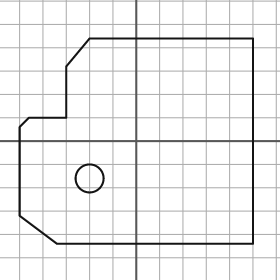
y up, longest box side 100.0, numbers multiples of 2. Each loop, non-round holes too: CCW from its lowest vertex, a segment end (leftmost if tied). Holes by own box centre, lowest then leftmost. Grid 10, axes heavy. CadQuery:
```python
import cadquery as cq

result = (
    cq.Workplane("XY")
    .moveTo(-34.0, -44.0)
    .lineTo(50.0, -44.0)
    .lineTo(50.0, 44.0)
    .lineTo(-20.0, 44.0)
    .lineTo(-30.0, 32.0)
    .lineTo(-30.0, 10.0)
    .lineTo(-46.0, 10.0)
    .lineTo(-50.0, 6.0)
    .lineTo(-50.0, -32.0)
    .close()
    .moveTo(-20.0, -16.0)
    .circle(6.0)
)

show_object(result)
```